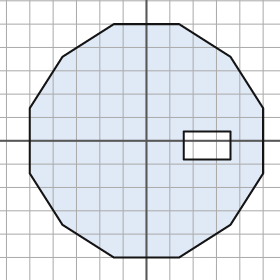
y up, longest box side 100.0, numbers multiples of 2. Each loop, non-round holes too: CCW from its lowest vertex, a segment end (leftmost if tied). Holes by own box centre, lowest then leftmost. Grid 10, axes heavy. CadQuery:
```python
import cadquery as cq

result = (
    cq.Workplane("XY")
    .moveTo(-14.0, -50.0)
    .lineTo(14.0, -50.0)
    .lineTo(36.0, -36.0)
    .lineTo(50.0, -14.0)
    .lineTo(50.0, 14.0)
    .lineTo(36.0, 36.0)
    .lineTo(14.0, 50.0)
    .lineTo(-14.0, 50.0)
    .lineTo(-36.0, 36.0)
    .lineTo(-50.0, 14.0)
    .lineTo(-50.0, -14.0)
    .lineTo(-36.0, -36.0)
    .close()
    .moveTo(16.0, -8.0)
    .lineTo(36.0, -8.0)
    .lineTo(36.0, 4.0)
    .lineTo(16.0, 4.0)
    .close()
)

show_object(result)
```